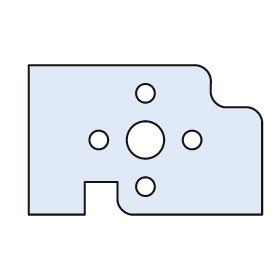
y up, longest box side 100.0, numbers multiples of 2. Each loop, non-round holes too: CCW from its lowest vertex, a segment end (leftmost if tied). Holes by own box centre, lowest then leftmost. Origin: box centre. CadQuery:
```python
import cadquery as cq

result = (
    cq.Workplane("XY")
    .moveTo(-50.0, -32.0)
    .lineTo(-26.0, -32.0)
    .lineTo(-26.0, -18.0)
    .lineTo(-12.0, -18.0)
    .lineTo(-12.0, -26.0)
    .threePointArc((-10.0, -30.0), (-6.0, -32.0))
    .lineTo(50.0, -32.0)
    .lineTo(50.0, 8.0)
    .threePointArc((48.0, 12.0), (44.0, 14.0))
    .lineTo(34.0, 14.0)
    .threePointArc((30.0, 16.0), (28.0, 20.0))
    .lineTo(28.0, 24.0)
    .threePointArc((26.0, 30.0), (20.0, 32.0))
    .lineTo(-50.0, 32.0)
    .close()
    .moveTo(0.0, -20.0)
    .circle(4.0)
    .moveTo(-20.0, 0.0)
    .circle(4.0)
    .moveTo(0.0, 0.0)
    .circle(8.0)
    .moveTo(20.0, 0.0)
    .circle(4.0)
    .moveTo(0.0, 20.0)
    .circle(4.0)
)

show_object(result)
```